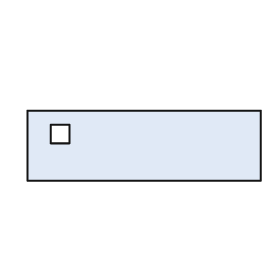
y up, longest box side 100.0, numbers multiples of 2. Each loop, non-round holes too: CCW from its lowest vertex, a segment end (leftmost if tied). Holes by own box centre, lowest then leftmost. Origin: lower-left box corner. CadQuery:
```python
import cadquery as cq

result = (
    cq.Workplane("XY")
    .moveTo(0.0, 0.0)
    .lineTo(100.0, 0.0)
    .lineTo(100.0, 30.0)
    .lineTo(0.0, 30.0)
    .close()
    .moveTo(10.0, 16.0)
    .lineTo(18.0, 16.0)
    .lineTo(18.0, 24.0)
    .lineTo(10.0, 24.0)
    .close()
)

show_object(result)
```